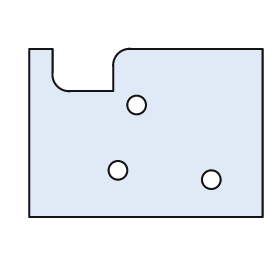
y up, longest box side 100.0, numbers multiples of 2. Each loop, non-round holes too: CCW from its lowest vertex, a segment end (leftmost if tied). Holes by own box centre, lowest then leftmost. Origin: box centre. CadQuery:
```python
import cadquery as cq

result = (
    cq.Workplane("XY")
    .moveTo(-50.0, -36.0)
    .lineTo(50.0, -36.0)
    .lineTo(50.0, 36.0)
    .lineTo(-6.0, 36.0)
    .threePointArc((-12.0, 34.0), (-14.0, 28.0))
    .lineTo(-14.0, 18.0)
    .lineTo(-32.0, 18.0)
    .threePointArc((-38.0, 20.0), (-40.0, 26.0))
    .lineTo(-40.0, 36.0)
    .lineTo(-50.0, 36.0)
    .close()
    .moveTo(28.0, -20.0)
    .circle(4.0)
    .moveTo(-12.0, -16.0)
    .circle(4.0)
    .moveTo(-4.0, 12.0)
    .circle(4.0)
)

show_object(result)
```